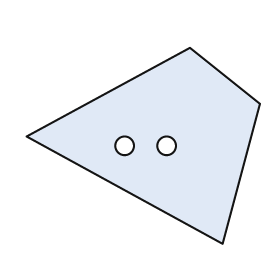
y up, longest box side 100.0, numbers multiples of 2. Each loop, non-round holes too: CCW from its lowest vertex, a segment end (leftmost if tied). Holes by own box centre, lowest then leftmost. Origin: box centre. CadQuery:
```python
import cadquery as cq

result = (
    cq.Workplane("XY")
    .moveTo(34.0, -42.0)
    .lineTo(50.0, 18.0)
    .lineTo(20.0, 42.0)
    .lineTo(-50.0, 4.0)
    .close()
    .moveTo(-8.0, 0.0)
    .circle(4.0)
    .moveTo(10.0, 0.0)
    .circle(4.0)
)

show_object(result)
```